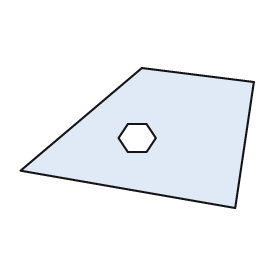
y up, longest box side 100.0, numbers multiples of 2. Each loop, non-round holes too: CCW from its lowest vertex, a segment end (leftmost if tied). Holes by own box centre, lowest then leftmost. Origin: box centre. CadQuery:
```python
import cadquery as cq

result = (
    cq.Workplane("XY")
    .moveTo(42.0, -30.0)
    .lineTo(50.0, 24.0)
    .lineTo(2.0, 30.0)
    .lineTo(-50.0, -14.0)
    .close()
    .moveTo(-4.0, -6.0)
    .lineTo(4.0, -6.0)
    .lineTo(8.0, 0.0)
    .lineTo(4.0, 6.0)
    .lineTo(-4.0, 6.0)
    .lineTo(-8.0, 0.0)
    .close()
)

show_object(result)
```